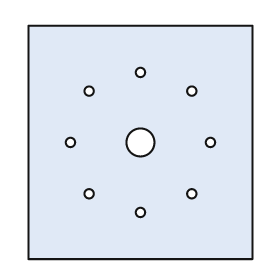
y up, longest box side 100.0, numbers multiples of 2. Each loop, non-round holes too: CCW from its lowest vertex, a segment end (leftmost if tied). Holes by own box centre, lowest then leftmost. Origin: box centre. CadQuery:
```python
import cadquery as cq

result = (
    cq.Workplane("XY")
    .moveTo(-48.0, -50.0)
    .lineTo(48.0, -50.0)
    .lineTo(48.0, 50.0)
    .lineTo(-48.0, 50.0)
    .close()
    .moveTo(0.0, -30.0)
    .circle(2.0)
    .moveTo(-22.0, -22.0)
    .circle(2.0)
    .moveTo(22.0, -22.0)
    .circle(2.0)
    .moveTo(-30.0, 0.0)
    .circle(2.0)
    .moveTo(0.0, 0.0)
    .circle(6.0)
    .moveTo(30.0, 0.0)
    .circle(2.0)
    .moveTo(-22.0, 22.0)
    .circle(2.0)
    .moveTo(22.0, 22.0)
    .circle(2.0)
    .moveTo(0.0, 30.0)
    .circle(2.0)
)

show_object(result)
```